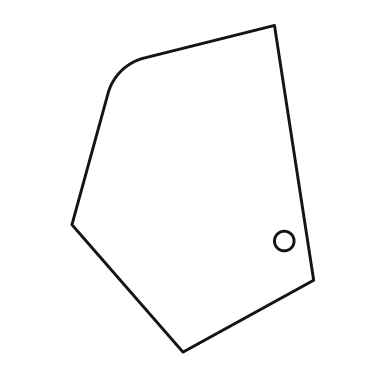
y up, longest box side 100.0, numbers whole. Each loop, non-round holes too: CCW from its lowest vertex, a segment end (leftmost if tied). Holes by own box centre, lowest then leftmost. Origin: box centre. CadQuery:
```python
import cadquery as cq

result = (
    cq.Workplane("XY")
    .moveTo(-3.0, -50.0)
    .lineTo(37.0, -28.0)
    .lineTo(25.0, 50.0)
    .lineTo(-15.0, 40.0)
    .threePointArc((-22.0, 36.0), (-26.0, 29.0))
    .lineTo(-37.0, -11.0)
    .close()
    .moveTo(28.0, -16.0)
    .circle(3.0)
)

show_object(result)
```